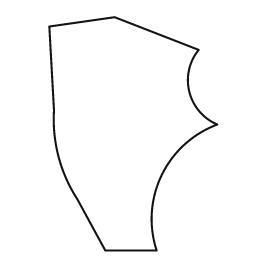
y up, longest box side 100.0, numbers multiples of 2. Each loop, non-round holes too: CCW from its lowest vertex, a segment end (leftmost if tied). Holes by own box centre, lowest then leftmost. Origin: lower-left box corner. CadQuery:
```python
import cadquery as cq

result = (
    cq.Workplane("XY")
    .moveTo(24.0, 0.0)
    .lineTo(46.0, 0.0)
    .threePointArc((48.0, 32.0), (72.0, 54.0))
    .threePointArc((60.0, 68.0), (64.0, 86.0))
    .lineTo(28.0, 100.0)
    .lineTo(0.0, 96.0)
    .lineTo(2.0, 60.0)
    .threePointArc((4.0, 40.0), (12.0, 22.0))
    .close()
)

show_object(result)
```